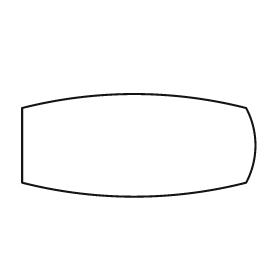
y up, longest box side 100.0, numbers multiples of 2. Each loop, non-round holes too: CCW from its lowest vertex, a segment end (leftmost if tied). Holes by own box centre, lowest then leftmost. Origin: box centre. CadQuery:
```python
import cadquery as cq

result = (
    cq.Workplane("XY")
    .moveTo(-50.0, -16.0)
    .threePointArc((-2.0, -22.0), (46.0, -16.0))
    .threePointArc((50.0, 0.0), (46.0, 16.0))
    .threePointArc((-2.0, 22.0), (-50.0, 16.0))
    .close()
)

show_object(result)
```